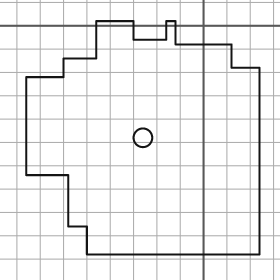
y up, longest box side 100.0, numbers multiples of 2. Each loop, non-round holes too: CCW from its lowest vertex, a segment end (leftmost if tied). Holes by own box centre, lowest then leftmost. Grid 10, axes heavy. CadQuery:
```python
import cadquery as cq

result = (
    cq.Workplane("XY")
    .moveTo(-50.0, -98.0)
    .lineTo(24.0, -98.0)
    .lineTo(24.0, -18.0)
    .lineTo(12.0, -18.0)
    .lineTo(12.0, -8.0)
    .lineTo(-12.0, -8.0)
    .lineTo(-12.0, 2.0)
    .lineTo(-16.0, 2.0)
    .lineTo(-16.0, -6.0)
    .lineTo(-30.0, -6.0)
    .lineTo(-30.0, 2.0)
    .lineTo(-46.0, 2.0)
    .lineTo(-46.0, -14.0)
    .lineTo(-60.0, -14.0)
    .lineTo(-60.0, -22.0)
    .lineTo(-76.0, -22.0)
    .lineTo(-76.0, -64.0)
    .lineTo(-58.0, -64.0)
    .lineTo(-58.0, -86.0)
    .lineTo(-50.0, -86.0)
    .close()
    .moveTo(-26.0, -48.0)
    .circle(4.0)
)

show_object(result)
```